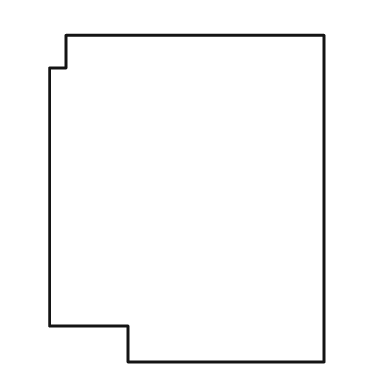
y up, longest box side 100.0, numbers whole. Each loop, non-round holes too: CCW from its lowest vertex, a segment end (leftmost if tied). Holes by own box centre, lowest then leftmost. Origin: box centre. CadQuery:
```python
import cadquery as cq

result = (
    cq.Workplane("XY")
    .moveTo(-18.0, -50.0)
    .lineTo(42.0, -50.0)
    .lineTo(42.0, 50.0)
    .lineTo(-37.0, 50.0)
    .lineTo(-37.0, 40.0)
    .lineTo(-42.0, 40.0)
    .lineTo(-42.0, -39.0)
    .lineTo(-18.0, -39.0)
    .close()
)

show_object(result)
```